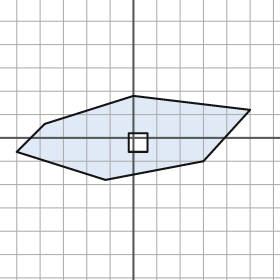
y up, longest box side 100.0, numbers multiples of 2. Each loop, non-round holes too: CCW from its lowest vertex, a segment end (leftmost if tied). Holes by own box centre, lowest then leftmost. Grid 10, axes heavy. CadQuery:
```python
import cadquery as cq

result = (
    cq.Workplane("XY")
    .moveTo(-12.0, -18.0)
    .lineTo(30.0, -10.0)
    .lineTo(50.0, 12.0)
    .lineTo(0.0, 18.0)
    .lineTo(-38.0, 6.0)
    .lineTo(-50.0, -6.0)
    .close()
    .moveTo(-2.0, -6.0)
    .lineTo(6.0, -6.0)
    .lineTo(6.0, 2.0)
    .lineTo(-2.0, 2.0)
    .close()
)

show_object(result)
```